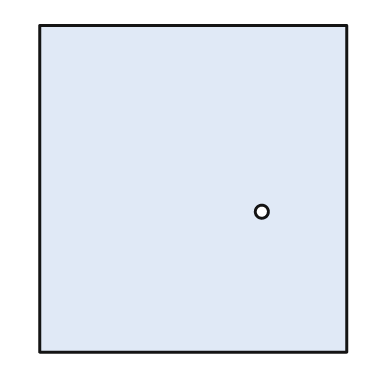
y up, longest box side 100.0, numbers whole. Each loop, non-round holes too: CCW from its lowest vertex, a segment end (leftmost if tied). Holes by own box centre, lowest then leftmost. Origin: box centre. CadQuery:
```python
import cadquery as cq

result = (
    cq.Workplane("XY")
    .moveTo(-47.0, -50.0)
    .lineTo(47.0, -50.0)
    .lineTo(47.0, 50.0)
    .lineTo(-47.0, 50.0)
    .close()
    .moveTo(21.0, -7.0)
    .circle(2.0)
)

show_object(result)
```